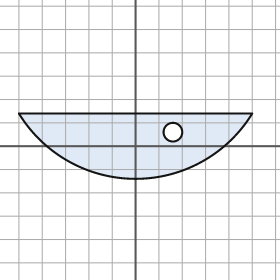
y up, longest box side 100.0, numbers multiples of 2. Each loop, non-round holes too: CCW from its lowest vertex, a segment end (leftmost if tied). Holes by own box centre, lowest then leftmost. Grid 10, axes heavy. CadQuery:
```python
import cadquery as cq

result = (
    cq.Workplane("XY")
    .moveTo(-50.0, 14.0)
    .threePointArc((0.0, -14.0), (50.0, 14.0))
    .close()
    .moveTo(16.0, 6.0)
    .circle(4.0)
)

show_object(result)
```